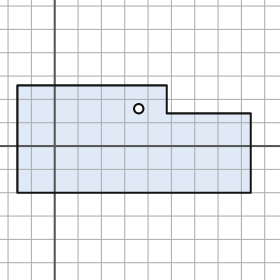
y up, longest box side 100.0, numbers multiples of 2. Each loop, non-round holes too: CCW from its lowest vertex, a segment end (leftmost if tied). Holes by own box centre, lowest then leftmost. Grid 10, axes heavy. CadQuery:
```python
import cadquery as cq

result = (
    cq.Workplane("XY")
    .moveTo(-16.0, -20.0)
    .lineTo(84.0, -20.0)
    .lineTo(84.0, 14.0)
    .lineTo(48.0, 14.0)
    .lineTo(48.0, 26.0)
    .lineTo(-16.0, 26.0)
    .close()
    .moveTo(36.0, 16.0)
    .circle(2.0)
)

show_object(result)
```